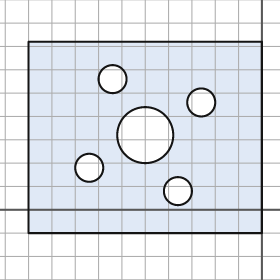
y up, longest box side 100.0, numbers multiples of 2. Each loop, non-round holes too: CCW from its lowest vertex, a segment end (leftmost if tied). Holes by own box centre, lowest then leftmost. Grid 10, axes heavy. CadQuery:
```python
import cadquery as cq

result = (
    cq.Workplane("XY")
    .moveTo(-100.0, -10.0)
    .lineTo(0.0, -10.0)
    .lineTo(0.0, 72.0)
    .lineTo(-100.0, 72.0)
    .close()
    .moveTo(-36.0, 8.0)
    .circle(6.0)
    .moveTo(-74.0, 18.0)
    .circle(6.0)
    .moveTo(-50.0, 32.0)
    .circle(12.0)
    .moveTo(-26.0, 46.0)
    .circle(6.0)
    .moveTo(-64.0, 56.0)
    .circle(6.0)
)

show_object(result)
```